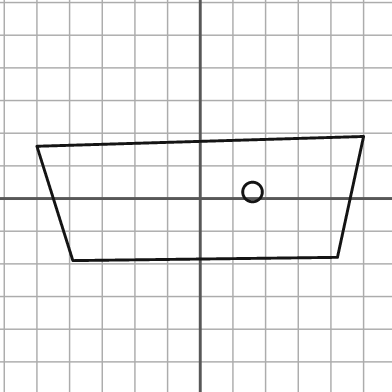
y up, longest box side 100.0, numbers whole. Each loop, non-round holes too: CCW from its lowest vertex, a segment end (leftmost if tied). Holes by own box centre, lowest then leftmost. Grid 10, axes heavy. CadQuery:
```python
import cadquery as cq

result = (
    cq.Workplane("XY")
    .moveTo(-39.0, -19.0)
    .lineTo(42.0, -18.0)
    .lineTo(50.0, 19.0)
    .lineTo(-50.0, 16.0)
    .close()
    .moveTo(16.0, 2.0)
    .circle(3.0)
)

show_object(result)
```